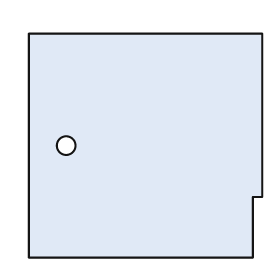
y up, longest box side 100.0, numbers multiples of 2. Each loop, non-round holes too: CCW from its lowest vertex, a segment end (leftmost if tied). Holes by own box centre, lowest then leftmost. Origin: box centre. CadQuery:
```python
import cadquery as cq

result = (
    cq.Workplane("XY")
    .moveTo(-50.0, -48.0)
    .lineTo(46.0, -48.0)
    .lineTo(46.0, -22.0)
    .lineTo(50.0, -22.0)
    .lineTo(50.0, 48.0)
    .lineTo(-50.0, 48.0)
    .close()
    .moveTo(-34.0, 0.0)
    .circle(4.0)
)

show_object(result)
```